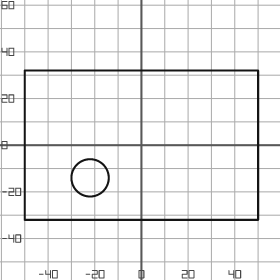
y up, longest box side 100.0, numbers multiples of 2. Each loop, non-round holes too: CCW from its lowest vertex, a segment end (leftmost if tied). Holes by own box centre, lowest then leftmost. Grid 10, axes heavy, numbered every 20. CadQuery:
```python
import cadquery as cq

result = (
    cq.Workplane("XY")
    .moveTo(-50.0, -32.0)
    .lineTo(50.0, -32.0)
    .lineTo(50.0, 32.0)
    .lineTo(-50.0, 32.0)
    .close()
    .moveTo(-22.0, -14.0)
    .circle(8.0)
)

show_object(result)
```